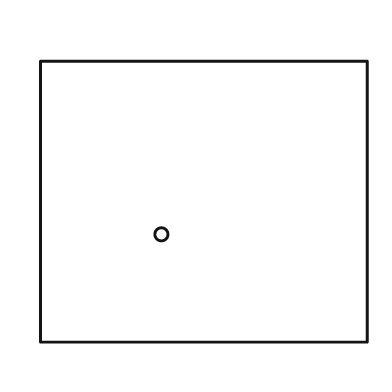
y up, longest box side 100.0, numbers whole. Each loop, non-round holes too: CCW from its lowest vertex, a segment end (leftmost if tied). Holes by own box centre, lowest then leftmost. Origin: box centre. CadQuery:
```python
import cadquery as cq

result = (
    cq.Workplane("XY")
    .moveTo(-50.0, -43.0)
    .lineTo(50.0, -43.0)
    .lineTo(50.0, 43.0)
    .lineTo(-50.0, 43.0)
    .close()
    .moveTo(-13.0, -10.0)
    .circle(2.0)
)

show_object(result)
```